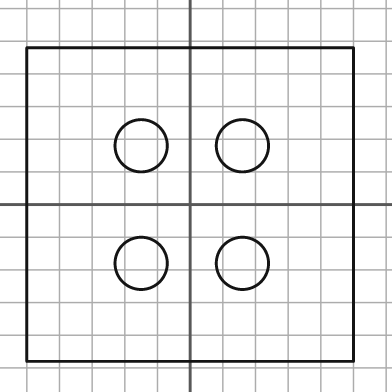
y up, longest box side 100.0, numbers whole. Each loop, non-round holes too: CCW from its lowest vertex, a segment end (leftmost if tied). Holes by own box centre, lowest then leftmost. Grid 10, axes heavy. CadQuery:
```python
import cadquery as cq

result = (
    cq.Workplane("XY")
    .moveTo(-50.0, -48.0)
    .lineTo(50.0, -48.0)
    .lineTo(50.0, 48.0)
    .lineTo(-50.0, 48.0)
    .close()
    .moveTo(-15.0, -18.0)
    .circle(8.0)
    .moveTo(16.0, -18.0)
    .circle(8.0)
    .moveTo(-15.0, 18.0)
    .circle(8.0)
    .moveTo(16.0, 18.0)
    .circle(8.0)
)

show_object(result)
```